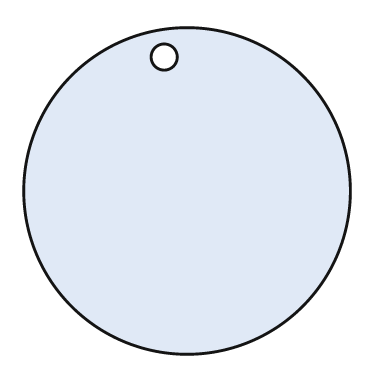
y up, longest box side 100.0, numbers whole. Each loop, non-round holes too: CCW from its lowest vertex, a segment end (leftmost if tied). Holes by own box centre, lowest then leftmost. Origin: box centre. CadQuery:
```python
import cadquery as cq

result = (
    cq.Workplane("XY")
    .moveTo(0.0, 0.0)
    .circle(50.0)
    .moveTo(-7.0, 41.0)
    .circle(4.0)
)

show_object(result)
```